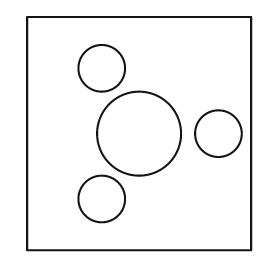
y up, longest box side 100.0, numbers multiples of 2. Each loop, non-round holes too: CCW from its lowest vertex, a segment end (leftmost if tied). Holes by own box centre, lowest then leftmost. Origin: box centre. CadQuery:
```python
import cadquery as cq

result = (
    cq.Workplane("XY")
    .moveTo(-48.0, -50.0)
    .lineTo(48.0, -50.0)
    .lineTo(48.0, 50.0)
    .lineTo(-48.0, 50.0)
    .close()
    .moveTo(-16.0, -28.0)
    .circle(10.0)
    .moveTo(0.0, 0.0)
    .circle(18.0)
    .moveTo(34.0, 0.0)
    .circle(10.0)
    .moveTo(-16.0, 28.0)
    .circle(10.0)
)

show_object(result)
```